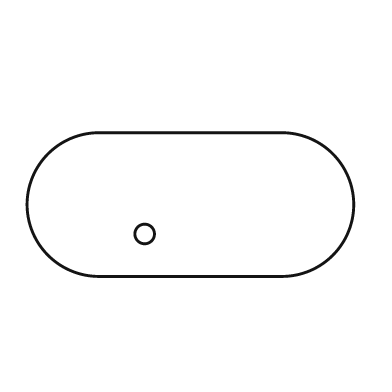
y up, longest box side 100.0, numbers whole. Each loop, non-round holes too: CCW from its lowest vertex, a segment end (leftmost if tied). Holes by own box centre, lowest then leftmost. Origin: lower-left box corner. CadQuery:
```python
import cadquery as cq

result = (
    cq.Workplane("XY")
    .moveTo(22.0, 0.0)
    .lineTo(78.0, 0.0)
    .threePointArc((100.0, 22.0), (78.0, 44.0))
    .lineTo(22.0, 44.0)
    .threePointArc((0.0, 22.0), (22.0, 0.0))
    .close()
    .moveTo(36.0, 13.0)
    .circle(3.0)
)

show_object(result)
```